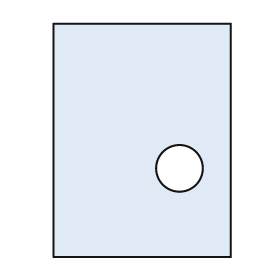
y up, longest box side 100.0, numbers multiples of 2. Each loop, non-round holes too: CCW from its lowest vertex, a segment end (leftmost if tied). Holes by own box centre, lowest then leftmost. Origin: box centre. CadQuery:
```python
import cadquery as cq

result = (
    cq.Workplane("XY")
    .moveTo(-38.0, -50.0)
    .lineTo(38.0, -50.0)
    .lineTo(38.0, 50.0)
    .lineTo(-38.0, 50.0)
    .close()
    .moveTo(16.0, -12.0)
    .circle(10.0)
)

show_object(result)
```